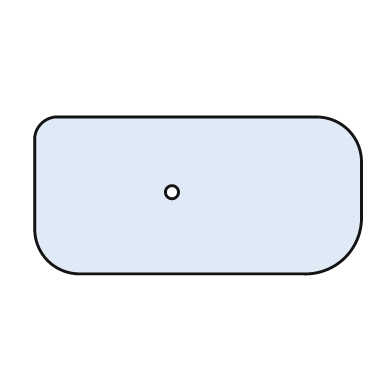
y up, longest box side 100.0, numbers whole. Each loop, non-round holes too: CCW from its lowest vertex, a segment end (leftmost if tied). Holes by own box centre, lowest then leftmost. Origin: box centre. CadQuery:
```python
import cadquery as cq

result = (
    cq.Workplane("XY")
    .moveTo(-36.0, -24.0)
    .lineTo(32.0, -24.0)
    .threePointArc((45.0, -19.0), (50.0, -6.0))
    .lineTo(50.0, 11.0)
    .threePointArc((46.0, 20.0), (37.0, 24.0))
    .lineTo(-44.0, 24.0)
    .threePointArc((-48.0, 22.0), (-50.0, 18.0))
    .lineTo(-50.0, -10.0)
    .threePointArc((-46.0, -20.0), (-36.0, -24.0))
    .close()
    .moveTo(-8.0, 1.0)
    .circle(2.0)
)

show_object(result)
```